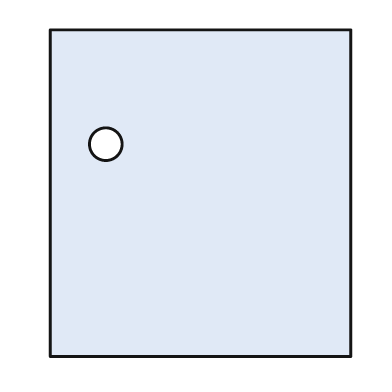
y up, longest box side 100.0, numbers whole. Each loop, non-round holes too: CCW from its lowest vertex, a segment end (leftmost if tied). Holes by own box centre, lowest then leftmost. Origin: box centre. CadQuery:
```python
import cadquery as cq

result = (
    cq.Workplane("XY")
    .moveTo(-46.0, -50.0)
    .lineTo(46.0, -50.0)
    .lineTo(46.0, 50.0)
    .lineTo(-46.0, 50.0)
    .close()
    .moveTo(-29.0, 15.0)
    .circle(5.0)
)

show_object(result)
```